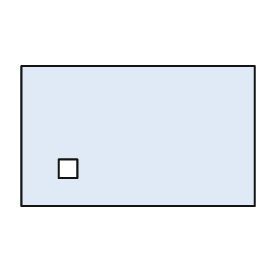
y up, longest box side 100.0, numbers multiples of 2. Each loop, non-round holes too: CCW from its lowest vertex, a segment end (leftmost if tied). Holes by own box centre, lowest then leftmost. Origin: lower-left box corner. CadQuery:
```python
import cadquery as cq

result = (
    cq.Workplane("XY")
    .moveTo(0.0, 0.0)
    .lineTo(100.0, 0.0)
    .lineTo(100.0, 60.0)
    .lineTo(0.0, 60.0)
    .close()
    .moveTo(16.0, 12.0)
    .lineTo(24.0, 12.0)
    .lineTo(24.0, 20.0)
    .lineTo(16.0, 20.0)
    .close()
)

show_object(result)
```